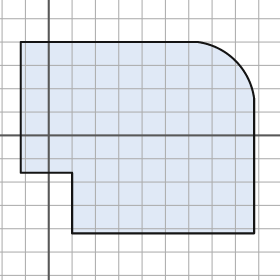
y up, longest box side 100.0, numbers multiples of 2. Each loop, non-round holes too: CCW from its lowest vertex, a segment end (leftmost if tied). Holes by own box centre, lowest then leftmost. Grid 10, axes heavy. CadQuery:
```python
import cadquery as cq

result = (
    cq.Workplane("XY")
    .moveTo(10.0, -42.0)
    .lineTo(88.0, -42.0)
    .lineTo(88.0, 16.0)
    .threePointArc((80.0, 32.0), (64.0, 40.0))
    .lineTo(-12.0, 40.0)
    .lineTo(-12.0, -16.0)
    .lineTo(10.0, -16.0)
    .close()
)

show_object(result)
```